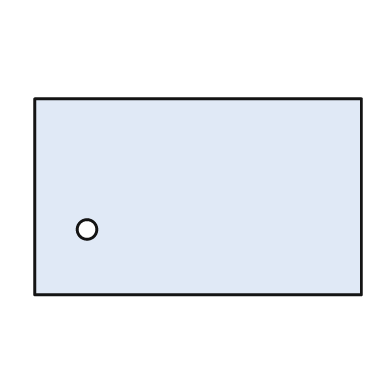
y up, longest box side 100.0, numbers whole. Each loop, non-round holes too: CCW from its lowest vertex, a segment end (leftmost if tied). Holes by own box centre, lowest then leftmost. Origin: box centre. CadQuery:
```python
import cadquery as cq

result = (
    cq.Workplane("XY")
    .moveTo(-50.0, -30.0)
    .lineTo(50.0, -30.0)
    .lineTo(50.0, 30.0)
    .lineTo(-50.0, 30.0)
    .close()
    .moveTo(-34.0, -10.0)
    .circle(3.0)
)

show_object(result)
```